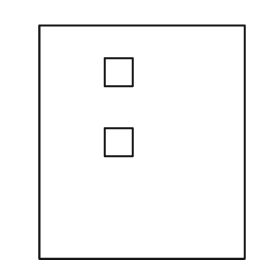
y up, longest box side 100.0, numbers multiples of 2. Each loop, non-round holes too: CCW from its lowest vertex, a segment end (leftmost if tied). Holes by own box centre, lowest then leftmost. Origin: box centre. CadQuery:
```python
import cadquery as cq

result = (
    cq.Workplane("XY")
    .moveTo(-44.0, -50.0)
    .lineTo(44.0, -50.0)
    .lineTo(44.0, 50.0)
    .lineTo(-44.0, 50.0)
    .close()
    .moveTo(-16.0, -6.0)
    .lineTo(-4.0, -6.0)
    .lineTo(-4.0, 6.0)
    .lineTo(-16.0, 6.0)
    .close()
    .moveTo(-16.0, 24.0)
    .lineTo(-4.0, 24.0)
    .lineTo(-4.0, 36.0)
    .lineTo(-16.0, 36.0)
    .close()
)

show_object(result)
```